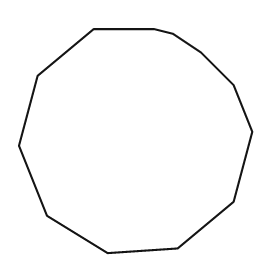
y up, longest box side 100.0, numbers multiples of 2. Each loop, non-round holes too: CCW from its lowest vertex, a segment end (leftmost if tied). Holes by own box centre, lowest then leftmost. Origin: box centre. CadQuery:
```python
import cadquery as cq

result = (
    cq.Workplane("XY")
    .moveTo(-12.0, -48.0)
    .lineTo(18.0, -46.0)
    .lineTo(42.0, -26.0)
    .lineTo(50.0, 4.0)
    .lineTo(42.0, 24.0)
    .lineTo(28.0, 38.0)
    .lineTo(16.0, 46.0)
    .lineTo(8.0, 48.0)
    .lineTo(-18.0, 48.0)
    .lineTo(-42.0, 28.0)
    .lineTo(-50.0, -2.0)
    .lineTo(-38.0, -32.0)
    .close()
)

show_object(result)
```